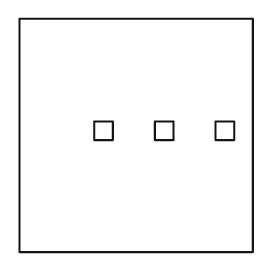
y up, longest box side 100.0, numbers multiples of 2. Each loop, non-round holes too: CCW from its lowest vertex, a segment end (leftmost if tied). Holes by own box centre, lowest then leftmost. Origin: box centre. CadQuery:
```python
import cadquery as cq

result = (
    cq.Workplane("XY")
    .moveTo(-50.0, -50.0)
    .lineTo(50.0, -50.0)
    .lineTo(50.0, 50.0)
    .lineTo(-50.0, 50.0)
    .close()
    .moveTo(-18.0, -2.0)
    .lineTo(-10.0, -2.0)
    .lineTo(-10.0, 6.0)
    .lineTo(-18.0, 6.0)
    .close()
    .moveTo(8.0, -2.0)
    .lineTo(16.0, -2.0)
    .lineTo(16.0, 6.0)
    .lineTo(8.0, 6.0)
    .close()
    .moveTo(34.0, -2.0)
    .lineTo(42.0, -2.0)
    .lineTo(42.0, 6.0)
    .lineTo(34.0, 6.0)
    .close()
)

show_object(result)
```